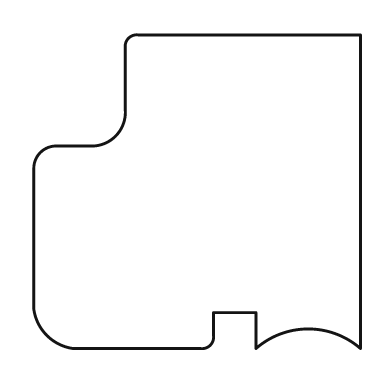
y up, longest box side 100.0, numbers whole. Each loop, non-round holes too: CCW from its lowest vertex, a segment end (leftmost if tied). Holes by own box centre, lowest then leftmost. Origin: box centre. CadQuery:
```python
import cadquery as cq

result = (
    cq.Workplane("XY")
    .moveTo(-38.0, -48.0)
    .lineTo(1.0, -48.0)
    .threePointArc((4.0, -47.0), (5.0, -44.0))
    .lineTo(5.0, -37.0)
    .lineTo(18.0, -37.0)
    .lineTo(18.0, -48.0)
    .threePointArc((34.0, -42.0), (50.0, -48.0))
    .lineTo(50.0, 48.0)
    .lineTo(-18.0, 48.0)
    .threePointArc((-21.0, 47.0), (-22.0, 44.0))
    .lineTo(-22.0, 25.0)
    .threePointArc((-25.0, 17.0), (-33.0, 14.0))
    .lineTo(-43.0, 14.0)
    .threePointArc((-48.0, 12.0), (-50.0, 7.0))
    .lineTo(-50.0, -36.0)
    .threePointArc((-46.0, -44.0), (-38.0, -48.0))
    .close()
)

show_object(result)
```